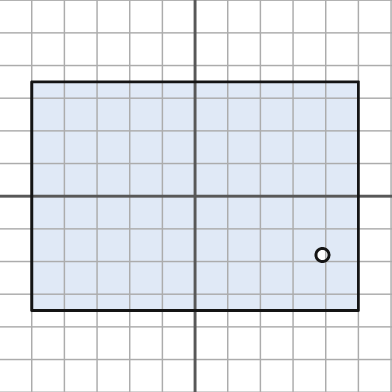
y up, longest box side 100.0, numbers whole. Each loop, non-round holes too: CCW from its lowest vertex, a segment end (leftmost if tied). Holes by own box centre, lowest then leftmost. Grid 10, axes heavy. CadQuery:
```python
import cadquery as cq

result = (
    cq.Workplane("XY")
    .moveTo(-50.0, -35.0)
    .lineTo(50.0, -35.0)
    .lineTo(50.0, 35.0)
    .lineTo(-50.0, 35.0)
    .close()
    .moveTo(39.0, -18.0)
    .circle(2.0)
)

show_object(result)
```